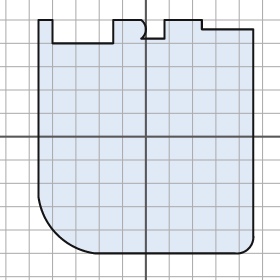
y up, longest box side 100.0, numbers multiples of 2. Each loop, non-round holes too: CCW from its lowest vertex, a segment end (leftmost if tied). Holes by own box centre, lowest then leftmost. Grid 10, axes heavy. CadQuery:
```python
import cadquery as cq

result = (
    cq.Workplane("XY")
    .moveTo(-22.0, -50.0)
    .lineTo(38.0, -50.0)
    .threePointArc((44.0, -48.0), (46.0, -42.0))
    .lineTo(46.0, 46.0)
    .lineTo(24.0, 46.0)
    .lineTo(24.0, 50.0)
    .lineTo(8.0, 50.0)
    .lineTo(8.0, 42.0)
    .lineTo(-2.0, 42.0)
    .threePointArc((0.0, 46.0), (-2.0, 50.0))
    .lineTo(-14.0, 50.0)
    .lineTo(-14.0, 40.0)
    .lineTo(-40.0, 40.0)
    .lineTo(-40.0, 50.0)
    .lineTo(-46.0, 50.0)
    .lineTo(-46.0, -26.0)
    .threePointArc((-38.0, -42.0), (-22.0, -50.0))
    .close()
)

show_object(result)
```